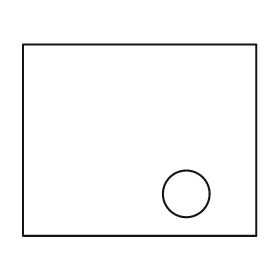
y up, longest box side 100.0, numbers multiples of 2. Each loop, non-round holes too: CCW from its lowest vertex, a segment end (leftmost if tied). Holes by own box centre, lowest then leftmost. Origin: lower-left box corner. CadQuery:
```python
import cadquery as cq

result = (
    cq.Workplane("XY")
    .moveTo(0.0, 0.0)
    .lineTo(100.0, 0.0)
    .lineTo(100.0, 82.0)
    .lineTo(0.0, 82.0)
    .close()
    .moveTo(70.0, 18.0)
    .circle(10.0)
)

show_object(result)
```